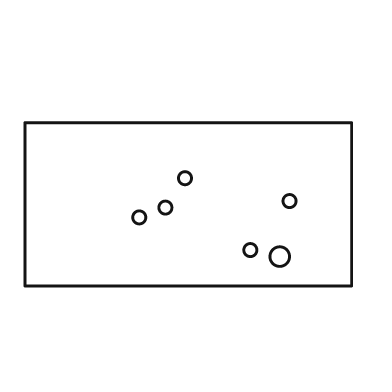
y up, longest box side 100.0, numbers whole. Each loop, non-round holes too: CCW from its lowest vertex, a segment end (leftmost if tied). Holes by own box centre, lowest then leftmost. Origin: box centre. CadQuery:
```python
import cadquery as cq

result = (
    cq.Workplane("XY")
    .moveTo(-50.0, -25.0)
    .lineTo(50.0, -25.0)
    .lineTo(50.0, 25.0)
    .lineTo(-50.0, 25.0)
    .close()
    .moveTo(28.0, -16.0)
    .circle(3.0)
    .moveTo(19.0, -14.0)
    .circle(2.0)
    .moveTo(-15.0, -4.0)
    .circle(2.0)
    .moveTo(-7.0, -1.0)
    .circle(2.0)
    .moveTo(31.0, 1.0)
    .circle(2.0)
    .moveTo(-1.0, 8.0)
    .circle(2.0)
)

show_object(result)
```